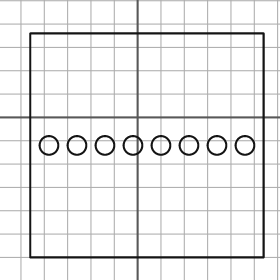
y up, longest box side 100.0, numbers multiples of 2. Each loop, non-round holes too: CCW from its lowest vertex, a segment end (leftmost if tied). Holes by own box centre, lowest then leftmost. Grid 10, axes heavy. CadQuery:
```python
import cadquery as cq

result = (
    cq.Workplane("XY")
    .moveTo(-46.0, -60.0)
    .lineTo(54.0, -60.0)
    .lineTo(54.0, 36.0)
    .lineTo(-46.0, 36.0)
    .close()
    .moveTo(-38.0, -12.0)
    .circle(4.0)
    .moveTo(-26.0, -12.0)
    .circle(4.0)
    .moveTo(-14.0, -12.0)
    .circle(4.0)
    .moveTo(-2.0, -12.0)
    .circle(4.0)
    .moveTo(10.0, -12.0)
    .circle(4.0)
    .moveTo(22.0, -12.0)
    .circle(4.0)
    .moveTo(34.0, -12.0)
    .circle(4.0)
    .moveTo(46.0, -12.0)
    .circle(4.0)
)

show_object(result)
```